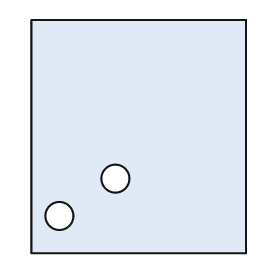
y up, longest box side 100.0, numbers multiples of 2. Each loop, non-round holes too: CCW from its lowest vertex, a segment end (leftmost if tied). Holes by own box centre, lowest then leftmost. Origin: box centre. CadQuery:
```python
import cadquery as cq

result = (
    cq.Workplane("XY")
    .moveTo(-46.0, -50.0)
    .lineTo(46.0, -50.0)
    .lineTo(46.0, 50.0)
    .lineTo(-46.0, 50.0)
    .close()
    .moveTo(-34.0, -34.0)
    .circle(6.0)
    .moveTo(-10.0, -18.0)
    .circle(6.0)
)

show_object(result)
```